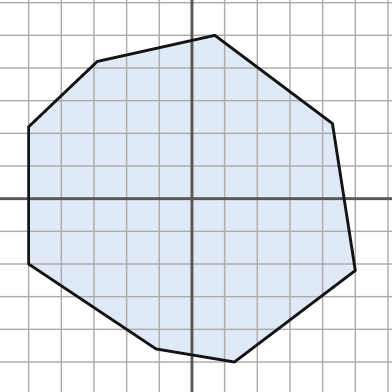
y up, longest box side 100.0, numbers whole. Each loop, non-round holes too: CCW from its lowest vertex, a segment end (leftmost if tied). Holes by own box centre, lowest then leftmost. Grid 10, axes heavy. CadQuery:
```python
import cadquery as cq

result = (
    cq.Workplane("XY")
    .moveTo(13.0, -50.0)
    .lineTo(50.0, -22.0)
    .lineTo(43.0, 23.0)
    .lineTo(7.0, 50.0)
    .lineTo(-29.0, 42.0)
    .lineTo(-50.0, 22.0)
    .lineTo(-50.0, -20.0)
    .lineTo(-11.0, -46.0)
    .close()
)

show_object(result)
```